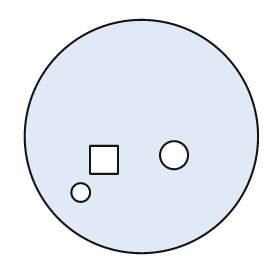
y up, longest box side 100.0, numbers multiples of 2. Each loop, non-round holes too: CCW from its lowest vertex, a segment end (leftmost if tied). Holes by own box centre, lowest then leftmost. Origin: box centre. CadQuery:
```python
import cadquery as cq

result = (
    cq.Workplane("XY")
    .moveTo(0.0, 0.0)
    .circle(50.0)
    .moveTo(-26.0, -24.0)
    .circle(4.0)
    .moveTo(-22.0, -16.0)
    .lineTo(-10.0, -16.0)
    .lineTo(-10.0, -4.0)
    .lineTo(-22.0, -4.0)
    .close()
    .moveTo(14.0, -8.0)
    .circle(6.0)
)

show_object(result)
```